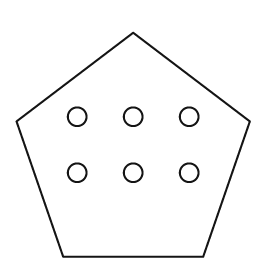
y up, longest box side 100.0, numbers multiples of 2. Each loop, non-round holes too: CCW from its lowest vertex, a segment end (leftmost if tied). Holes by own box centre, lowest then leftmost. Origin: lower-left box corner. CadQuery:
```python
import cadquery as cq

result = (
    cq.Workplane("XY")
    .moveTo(20.0, 0.0)
    .lineTo(80.0, 0.0)
    .lineTo(100.0, 58.0)
    .lineTo(50.0, 96.0)
    .lineTo(0.0, 58.0)
    .close()
    .moveTo(26.0, 36.0)
    .circle(4.0)
    .moveTo(50.0, 36.0)
    .circle(4.0)
    .moveTo(74.0, 36.0)
    .circle(4.0)
    .moveTo(26.0, 60.0)
    .circle(4.0)
    .moveTo(50.0, 60.0)
    .circle(4.0)
    .moveTo(74.0, 60.0)
    .circle(4.0)
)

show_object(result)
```